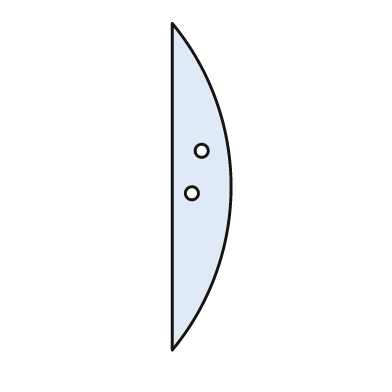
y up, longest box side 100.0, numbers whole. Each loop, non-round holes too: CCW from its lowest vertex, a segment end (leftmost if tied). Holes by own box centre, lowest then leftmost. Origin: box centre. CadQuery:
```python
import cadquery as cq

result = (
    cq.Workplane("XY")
    .moveTo(-9.0, -50.0)
    .threePointArc((9.0, 0.0), (-9.0, 50.0))
    .close()
    .moveTo(-3.0, -2.0)
    .circle(2.0)
    .moveTo(0.0, 11.0)
    .circle(2.0)
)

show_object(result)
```